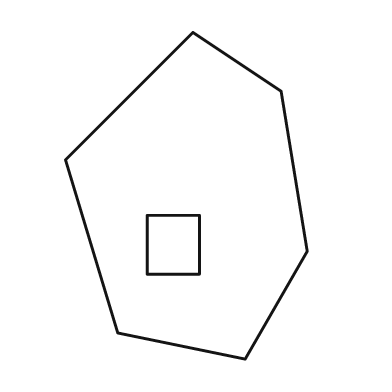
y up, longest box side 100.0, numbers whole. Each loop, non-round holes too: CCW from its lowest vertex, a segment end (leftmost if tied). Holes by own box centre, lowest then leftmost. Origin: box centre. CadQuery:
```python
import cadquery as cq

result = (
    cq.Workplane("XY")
    .moveTo(18.0, -50.0)
    .lineTo(37.0, -17.0)
    .lineTo(29.0, 32.0)
    .lineTo(2.0, 50.0)
    .lineTo(-37.0, 11.0)
    .lineTo(-21.0, -42.0)
    .close()
    .moveTo(-12.0, -24.0)
    .lineTo(4.0, -24.0)
    .lineTo(4.0, -6.0)
    .lineTo(-12.0, -6.0)
    .close()
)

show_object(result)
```